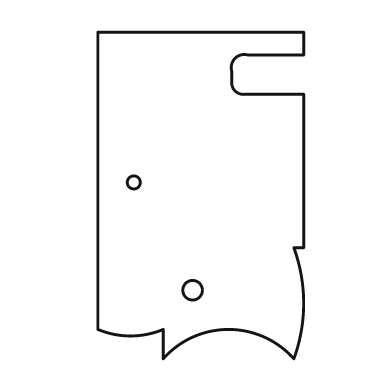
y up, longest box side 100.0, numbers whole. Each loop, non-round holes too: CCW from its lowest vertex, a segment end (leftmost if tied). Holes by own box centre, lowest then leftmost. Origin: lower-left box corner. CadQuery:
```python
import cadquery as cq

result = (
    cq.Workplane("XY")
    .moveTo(20.0, 0.0)
    .threePointArc((40.0, 9.0), (60.0, 0.0))
    .threePointArc((63.0, 17.0), (60.0, 34.0))
    .lineTo(63.0, 34.0)
    .lineTo(63.0, 81.0)
    .lineTo(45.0, 81.0)
    .threePointArc((42.0, 82.0), (41.0, 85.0))
    .lineTo(41.0, 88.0)
    .threePointArc((42.0, 92.0), (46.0, 93.0))
    .lineTo(63.0, 93.0)
    .lineTo(63.0, 100.0)
    .lineTo(0.0, 100.0)
    .lineTo(0.0, 9.0)
    .threePointArc((10.0, 7.0), (20.0, 9.0))
    .close()
    .moveTo(29.0, 21.0)
    .circle(3.0)
    .moveTo(11.0, 54.0)
    .circle(2.0)
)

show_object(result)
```